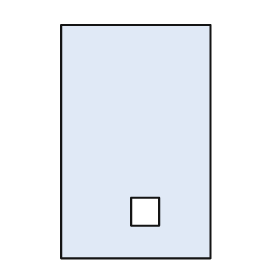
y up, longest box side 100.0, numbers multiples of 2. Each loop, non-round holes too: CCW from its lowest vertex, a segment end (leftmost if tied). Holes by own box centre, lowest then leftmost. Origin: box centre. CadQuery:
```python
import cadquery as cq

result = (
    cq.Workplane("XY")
    .moveTo(-32.0, -50.0)
    .lineTo(32.0, -50.0)
    .lineTo(32.0, 50.0)
    .lineTo(-32.0, 50.0)
    .close()
    .moveTo(-2.0, -36.0)
    .lineTo(10.0, -36.0)
    .lineTo(10.0, -24.0)
    .lineTo(-2.0, -24.0)
    .close()
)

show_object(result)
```